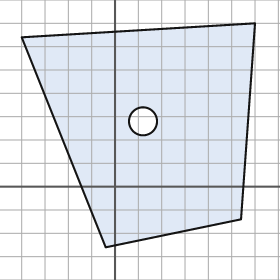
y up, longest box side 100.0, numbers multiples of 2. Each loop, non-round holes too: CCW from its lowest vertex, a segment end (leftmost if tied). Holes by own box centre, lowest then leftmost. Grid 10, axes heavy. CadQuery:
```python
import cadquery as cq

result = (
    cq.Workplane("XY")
    .moveTo(-4.0, -26.0)
    .lineTo(54.0, -14.0)
    .lineTo(60.0, 70.0)
    .lineTo(-40.0, 64.0)
    .close()
    .moveTo(12.0, 28.0)
    .circle(6.0)
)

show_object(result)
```